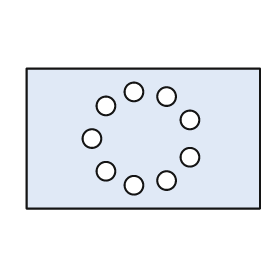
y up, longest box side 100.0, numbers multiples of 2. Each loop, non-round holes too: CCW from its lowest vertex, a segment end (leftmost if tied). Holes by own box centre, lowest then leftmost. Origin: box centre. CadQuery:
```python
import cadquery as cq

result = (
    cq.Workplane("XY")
    .moveTo(-50.0, -30.0)
    .lineTo(50.0, -30.0)
    .lineTo(50.0, 30.0)
    .lineTo(-50.0, 30.0)
    .close()
    .moveTo(-4.0, -20.0)
    .circle(4.0)
    .moveTo(10.0, -18.0)
    .circle(4.0)
    .moveTo(-16.0, -14.0)
    .circle(4.0)
    .moveTo(20.0, -8.0)
    .circle(4.0)
    .moveTo(-22.0, 0.0)
    .circle(4.0)
    .moveTo(20.0, 8.0)
    .circle(4.0)
    .moveTo(-16.0, 14.0)
    .circle(4.0)
    .moveTo(10.0, 18.0)
    .circle(4.0)
    .moveTo(-4.0, 20.0)
    .circle(4.0)
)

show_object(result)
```